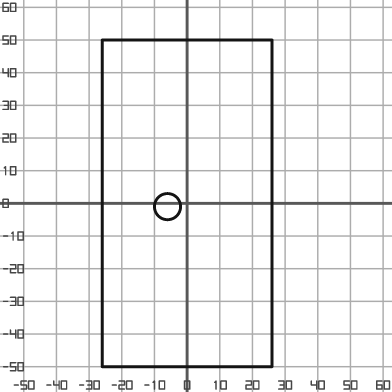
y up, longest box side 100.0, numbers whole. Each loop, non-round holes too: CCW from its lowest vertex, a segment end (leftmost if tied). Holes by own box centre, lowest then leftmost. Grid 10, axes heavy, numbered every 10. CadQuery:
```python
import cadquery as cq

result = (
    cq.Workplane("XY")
    .moveTo(-26.0, -50.0)
    .lineTo(26.0, -50.0)
    .lineTo(26.0, 50.0)
    .lineTo(-26.0, 50.0)
    .close()
    .moveTo(-6.0, -1.0)
    .circle(4.0)
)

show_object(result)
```